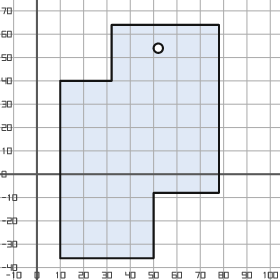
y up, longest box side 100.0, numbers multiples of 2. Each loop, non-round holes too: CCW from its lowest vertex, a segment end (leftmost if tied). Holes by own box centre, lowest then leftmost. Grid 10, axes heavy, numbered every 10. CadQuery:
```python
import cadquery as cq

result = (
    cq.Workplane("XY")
    .moveTo(10.0, -36.0)
    .lineTo(50.0, -36.0)
    .lineTo(50.0, -8.0)
    .lineTo(78.0, -8.0)
    .lineTo(78.0, 64.0)
    .lineTo(32.0, 64.0)
    .lineTo(32.0, 40.0)
    .lineTo(10.0, 40.0)
    .close()
    .moveTo(52.0, 54.0)
    .circle(2.0)
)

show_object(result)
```